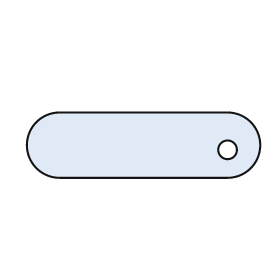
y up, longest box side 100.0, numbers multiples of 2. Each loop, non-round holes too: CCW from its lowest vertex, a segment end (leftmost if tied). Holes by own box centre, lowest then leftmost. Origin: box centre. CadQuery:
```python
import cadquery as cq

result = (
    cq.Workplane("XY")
    .moveTo(-36.0, -14.0)
    .lineTo(36.0, -14.0)
    .threePointArc((50.0, 0.0), (36.0, 14.0))
    .lineTo(-36.0, 14.0)
    .threePointArc((-50.0, 0.0), (-36.0, -14.0))
    .close()
    .moveTo(36.0, -2.0)
    .circle(4.0)
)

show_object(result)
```